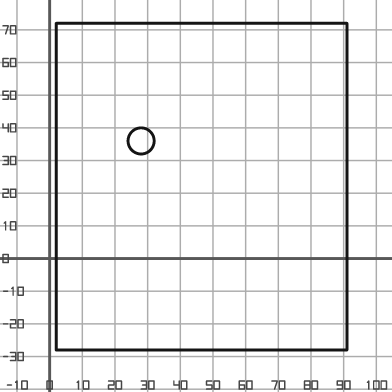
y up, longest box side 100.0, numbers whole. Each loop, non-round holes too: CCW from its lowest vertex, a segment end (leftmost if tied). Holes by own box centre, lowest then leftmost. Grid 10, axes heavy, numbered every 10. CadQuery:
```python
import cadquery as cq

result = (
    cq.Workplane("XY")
    .moveTo(2.0, -28.0)
    .lineTo(91.0, -28.0)
    .lineTo(91.0, 72.0)
    .lineTo(2.0, 72.0)
    .close()
    .moveTo(28.0, 36.0)
    .circle(4.0)
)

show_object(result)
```